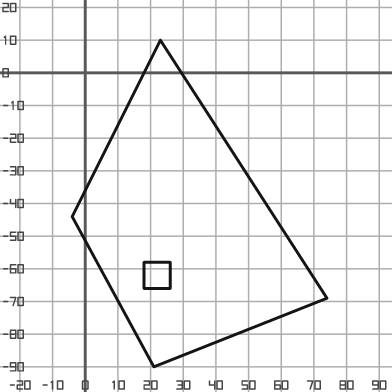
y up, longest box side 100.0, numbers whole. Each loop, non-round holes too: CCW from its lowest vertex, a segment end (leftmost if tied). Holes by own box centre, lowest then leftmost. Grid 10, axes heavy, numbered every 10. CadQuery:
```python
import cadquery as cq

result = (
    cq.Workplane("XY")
    .moveTo(21.0, -90.0)
    .lineTo(74.0, -69.0)
    .lineTo(23.0, 10.0)
    .lineTo(-4.0, -44.0)
    .close()
    .moveTo(18.0, -66.0)
    .lineTo(26.0, -66.0)
    .lineTo(26.0, -58.0)
    .lineTo(18.0, -58.0)
    .close()
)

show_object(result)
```